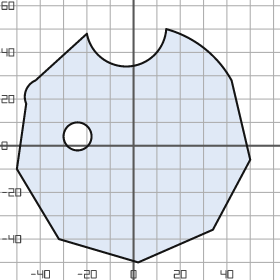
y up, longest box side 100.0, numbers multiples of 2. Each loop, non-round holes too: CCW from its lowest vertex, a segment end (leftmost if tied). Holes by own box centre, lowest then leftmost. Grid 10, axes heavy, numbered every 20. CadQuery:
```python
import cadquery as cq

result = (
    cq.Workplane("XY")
    .moveTo(2.0, -50.0)
    .lineTo(34.0, -36.0)
    .lineTo(50.0, -6.0)
    .lineTo(42.0, 28.0)
    .threePointArc((30.0, 42.0), (14.0, 50.0))
    .threePointArc((-2.0, 34.0), (-20.0, 48.0))
    .lineTo(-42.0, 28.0)
    .threePointArc((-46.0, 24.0), (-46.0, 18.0))
    .lineTo(-50.0, -10.0)
    .lineTo(-32.0, -40.0)
    .close()
    .moveTo(-24.0, 4.0)
    .circle(6.0)
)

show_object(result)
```